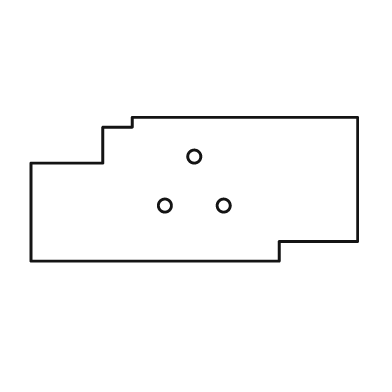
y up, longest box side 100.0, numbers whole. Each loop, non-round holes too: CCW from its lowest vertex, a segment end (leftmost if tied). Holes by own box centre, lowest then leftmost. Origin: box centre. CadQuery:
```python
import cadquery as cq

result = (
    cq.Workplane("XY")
    .moveTo(-50.0, -22.0)
    .lineTo(26.0, -22.0)
    .lineTo(26.0, -16.0)
    .lineTo(50.0, -16.0)
    .lineTo(50.0, 22.0)
    .lineTo(-19.0, 22.0)
    .lineTo(-19.0, 19.0)
    .lineTo(-28.0, 19.0)
    .lineTo(-28.0, 8.0)
    .lineTo(-50.0, 8.0)
    .close()
    .moveTo(-9.0, -5.0)
    .circle(2.0)
    .moveTo(9.0, -5.0)
    .circle(2.0)
    .moveTo(0.0, 10.0)
    .circle(2.0)
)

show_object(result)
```